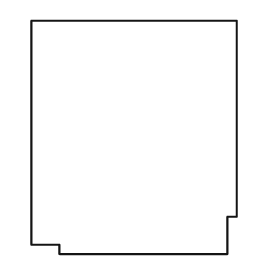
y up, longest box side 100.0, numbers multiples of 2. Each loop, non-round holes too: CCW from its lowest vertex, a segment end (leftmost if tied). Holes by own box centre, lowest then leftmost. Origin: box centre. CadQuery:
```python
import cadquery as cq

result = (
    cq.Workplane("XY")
    .moveTo(-32.0, -50.0)
    .lineTo(40.0, -50.0)
    .lineTo(40.0, -34.0)
    .lineTo(44.0, -34.0)
    .lineTo(44.0, 50.0)
    .lineTo(-44.0, 50.0)
    .lineTo(-44.0, -46.0)
    .lineTo(-32.0, -46.0)
    .close()
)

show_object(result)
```